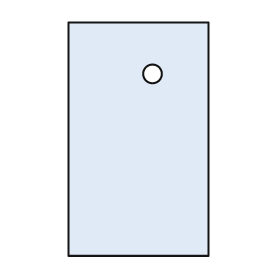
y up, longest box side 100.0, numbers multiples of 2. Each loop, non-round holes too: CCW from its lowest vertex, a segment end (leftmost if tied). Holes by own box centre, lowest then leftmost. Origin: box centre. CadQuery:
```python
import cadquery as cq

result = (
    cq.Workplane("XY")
    .moveTo(-30.0, -50.0)
    .lineTo(30.0, -50.0)
    .lineTo(30.0, 50.0)
    .lineTo(-30.0, 50.0)
    .close()
    .moveTo(6.0, 28.0)
    .circle(4.0)
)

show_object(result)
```